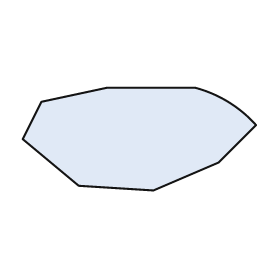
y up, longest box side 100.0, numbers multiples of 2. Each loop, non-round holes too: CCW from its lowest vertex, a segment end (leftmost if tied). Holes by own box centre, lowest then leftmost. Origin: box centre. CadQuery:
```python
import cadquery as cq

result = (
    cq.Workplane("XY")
    .moveTo(6.0, -22.0)
    .lineTo(34.0, -10.0)
    .lineTo(50.0, 6.0)
    .threePointArc((38.0, 16.0), (24.0, 22.0))
    .lineTo(-14.0, 22.0)
    .lineTo(-42.0, 16.0)
    .lineTo(-50.0, 0.0)
    .lineTo(-26.0, -20.0)
    .close()
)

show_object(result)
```